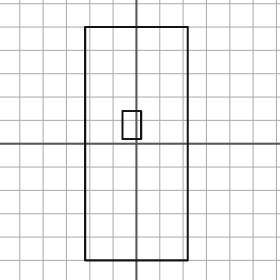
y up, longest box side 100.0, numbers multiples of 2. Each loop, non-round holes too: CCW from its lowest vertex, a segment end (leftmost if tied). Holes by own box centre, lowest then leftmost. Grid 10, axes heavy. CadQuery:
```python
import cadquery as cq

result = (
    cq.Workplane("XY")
    .moveTo(-22.0, -50.0)
    .lineTo(22.0, -50.0)
    .lineTo(22.0, 50.0)
    .lineTo(-22.0, 50.0)
    .close()
    .moveTo(-6.0, 2.0)
    .lineTo(2.0, 2.0)
    .lineTo(2.0, 14.0)
    .lineTo(-6.0, 14.0)
    .close()
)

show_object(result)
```